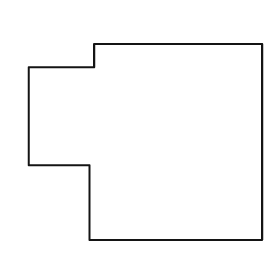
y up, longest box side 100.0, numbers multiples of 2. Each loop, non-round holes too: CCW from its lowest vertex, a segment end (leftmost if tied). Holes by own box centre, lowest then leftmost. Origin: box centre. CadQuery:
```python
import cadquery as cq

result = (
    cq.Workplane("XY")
    .moveTo(-24.0, -42.0)
    .lineTo(50.0, -42.0)
    .lineTo(50.0, 42.0)
    .lineTo(-22.0, 42.0)
    .lineTo(-22.0, 32.0)
    .lineTo(-50.0, 32.0)
    .lineTo(-50.0, -10.0)
    .lineTo(-24.0, -10.0)
    .close()
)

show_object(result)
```